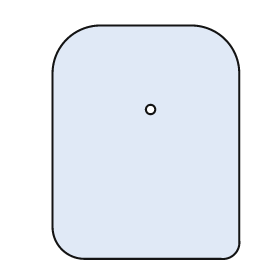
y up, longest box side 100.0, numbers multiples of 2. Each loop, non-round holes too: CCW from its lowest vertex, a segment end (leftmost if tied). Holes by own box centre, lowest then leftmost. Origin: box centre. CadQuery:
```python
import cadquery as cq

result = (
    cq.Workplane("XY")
    .moveTo(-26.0, -50.0)
    .lineTo(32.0, -50.0)
    .threePointArc((38.0, -48.0), (40.0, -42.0))
    .lineTo(40.0, 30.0)
    .threePointArc((34.0, 44.0), (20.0, 50.0))
    .lineTo(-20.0, 50.0)
    .threePointArc((-34.0, 44.0), (-40.0, 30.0))
    .lineTo(-40.0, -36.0)
    .threePointArc((-36.0, -46.0), (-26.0, -50.0))
    .close()
    .moveTo(2.0, 14.0)
    .circle(2.0)
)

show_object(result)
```